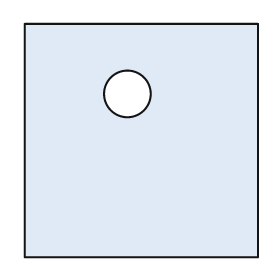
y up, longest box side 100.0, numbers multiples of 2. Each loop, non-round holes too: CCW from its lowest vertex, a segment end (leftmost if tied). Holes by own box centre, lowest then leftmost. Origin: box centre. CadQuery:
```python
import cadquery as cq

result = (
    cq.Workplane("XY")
    .moveTo(-50.0, -50.0)
    .lineTo(50.0, -50.0)
    .lineTo(50.0, 50.0)
    .lineTo(-50.0, 50.0)
    .close()
    .moveTo(-6.0, 20.0)
    .circle(10.0)
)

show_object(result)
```